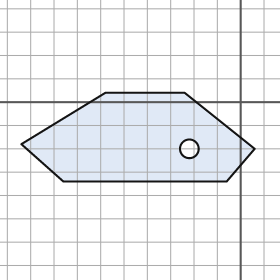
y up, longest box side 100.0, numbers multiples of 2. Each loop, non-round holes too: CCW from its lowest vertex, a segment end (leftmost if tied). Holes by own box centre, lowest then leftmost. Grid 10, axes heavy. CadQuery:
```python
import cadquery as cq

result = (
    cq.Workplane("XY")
    .moveTo(-76.0, -34.0)
    .lineTo(-6.0, -34.0)
    .lineTo(6.0, -20.0)
    .lineTo(-24.0, 4.0)
    .lineTo(-58.0, 4.0)
    .lineTo(-94.0, -18.0)
    .close()
    .moveTo(-22.0, -20.0)
    .circle(4.0)
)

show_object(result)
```